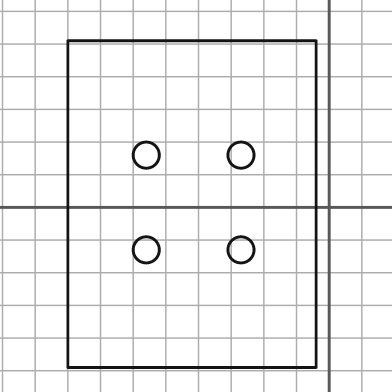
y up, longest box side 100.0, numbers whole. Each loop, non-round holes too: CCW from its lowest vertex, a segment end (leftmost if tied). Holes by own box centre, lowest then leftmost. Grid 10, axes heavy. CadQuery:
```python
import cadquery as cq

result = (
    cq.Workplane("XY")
    .moveTo(-80.0, -49.0)
    .lineTo(-4.0, -49.0)
    .lineTo(-4.0, 51.0)
    .lineTo(-80.0, 51.0)
    .close()
    .moveTo(-56.0, -13.0)
    .circle(4.0)
    .moveTo(-27.0, -13.0)
    .circle(4.0)
    .moveTo(-56.0, 16.0)
    .circle(4.0)
    .moveTo(-27.0, 16.0)
    .circle(4.0)
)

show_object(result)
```